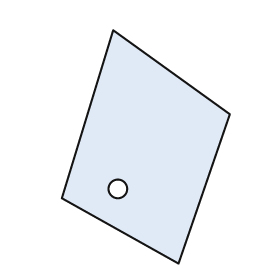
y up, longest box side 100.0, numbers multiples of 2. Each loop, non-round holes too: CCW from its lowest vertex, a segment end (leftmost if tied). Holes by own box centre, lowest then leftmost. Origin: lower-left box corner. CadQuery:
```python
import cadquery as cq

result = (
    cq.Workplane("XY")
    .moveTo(50.0, 0.0)
    .lineTo(72.0, 64.0)
    .lineTo(22.0, 100.0)
    .lineTo(0.0, 28.0)
    .close()
    .moveTo(24.0, 32.0)
    .circle(4.0)
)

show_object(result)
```